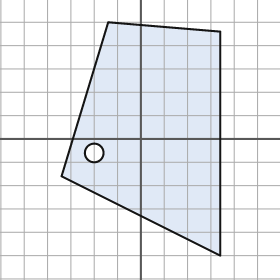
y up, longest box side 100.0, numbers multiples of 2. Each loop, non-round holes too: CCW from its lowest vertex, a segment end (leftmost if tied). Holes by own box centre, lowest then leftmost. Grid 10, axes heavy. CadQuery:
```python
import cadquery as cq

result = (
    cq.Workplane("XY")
    .moveTo(34.0, -50.0)
    .lineTo(34.0, 46.0)
    .lineTo(-14.0, 50.0)
    .lineTo(-34.0, -16.0)
    .close()
    .moveTo(-20.0, -6.0)
    .circle(4.0)
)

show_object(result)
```